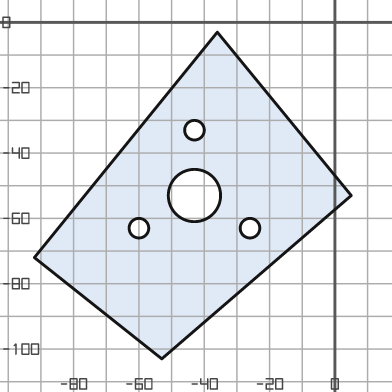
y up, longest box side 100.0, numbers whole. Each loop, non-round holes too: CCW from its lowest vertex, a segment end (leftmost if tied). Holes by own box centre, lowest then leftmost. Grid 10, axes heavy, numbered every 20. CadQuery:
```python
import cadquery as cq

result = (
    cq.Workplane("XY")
    .moveTo(-53.0, -103.0)
    .lineTo(5.0, -53.0)
    .lineTo(-36.0, -3.0)
    .lineTo(-92.0, -72.0)
    .close()
    .moveTo(-60.0, -63.0)
    .circle(3.0)
    .moveTo(-26.0, -63.0)
    .circle(3.0)
    .moveTo(-43.0, -53.0)
    .circle(8.0)
    .moveTo(-43.0, -33.0)
    .circle(3.0)
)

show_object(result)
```